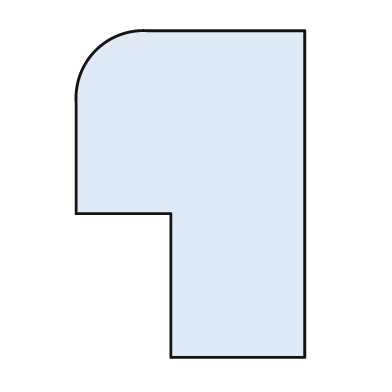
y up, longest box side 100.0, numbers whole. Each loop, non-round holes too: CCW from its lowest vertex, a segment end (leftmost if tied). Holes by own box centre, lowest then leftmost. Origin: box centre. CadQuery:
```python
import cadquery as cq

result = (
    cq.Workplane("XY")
    .moveTo(-6.0, -50.0)
    .lineTo(35.0, -50.0)
    .lineTo(35.0, 50.0)
    .lineTo(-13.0, 50.0)
    .threePointArc((-29.0, 44.0), (-35.0, 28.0))
    .lineTo(-35.0, -6.0)
    .lineTo(-6.0, -6.0)
    .close()
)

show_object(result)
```